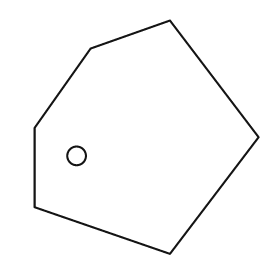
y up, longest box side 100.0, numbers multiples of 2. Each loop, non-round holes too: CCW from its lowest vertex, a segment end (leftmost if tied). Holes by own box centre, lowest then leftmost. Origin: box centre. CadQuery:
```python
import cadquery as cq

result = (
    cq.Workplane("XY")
    .moveTo(10.0, -50.0)
    .lineTo(48.0, 0.0)
    .lineTo(10.0, 50.0)
    .lineTo(-24.0, 38.0)
    .lineTo(-48.0, 4.0)
    .lineTo(-48.0, -30.0)
    .close()
    .moveTo(-30.0, -8.0)
    .circle(4.0)
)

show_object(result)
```